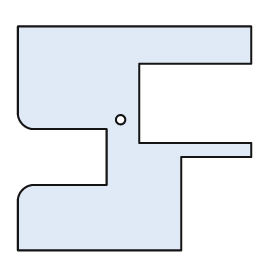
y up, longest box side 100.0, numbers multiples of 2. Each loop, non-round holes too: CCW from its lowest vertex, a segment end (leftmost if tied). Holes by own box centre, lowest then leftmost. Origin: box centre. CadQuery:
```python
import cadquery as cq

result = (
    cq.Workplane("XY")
    .moveTo(-50.0, -48.0)
    .lineTo(20.0, -48.0)
    .lineTo(20.0, -8.0)
    .lineTo(50.0, -8.0)
    .lineTo(50.0, -2.0)
    .lineTo(2.0, -2.0)
    .lineTo(2.0, 32.0)
    .lineTo(50.0, 32.0)
    .lineTo(50.0, 48.0)
    .lineTo(-50.0, 48.0)
    .lineTo(-50.0, 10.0)
    .threePointArc((-48.0, 6.0), (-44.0, 4.0))
    .lineTo(-12.0, 4.0)
    .lineTo(-12.0, -20.0)
    .lineTo(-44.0, -20.0)
    .threePointArc((-48.0, -22.0), (-50.0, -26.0))
    .close()
    .moveTo(-6.0, 8.0)
    .circle(2.0)
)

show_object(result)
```